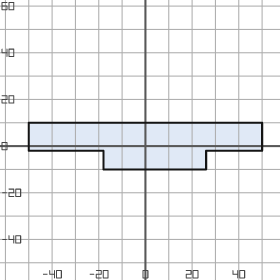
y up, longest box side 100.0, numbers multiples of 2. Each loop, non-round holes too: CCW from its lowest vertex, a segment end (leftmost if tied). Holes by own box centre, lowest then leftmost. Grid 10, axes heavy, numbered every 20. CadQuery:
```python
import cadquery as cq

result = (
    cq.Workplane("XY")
    .moveTo(-18.0, -10.0)
    .lineTo(26.0, -10.0)
    .lineTo(26.0, -2.0)
    .lineTo(50.0, -2.0)
    .lineTo(50.0, 10.0)
    .lineTo(-50.0, 10.0)
    .lineTo(-50.0, -2.0)
    .lineTo(-18.0, -2.0)
    .close()
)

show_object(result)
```